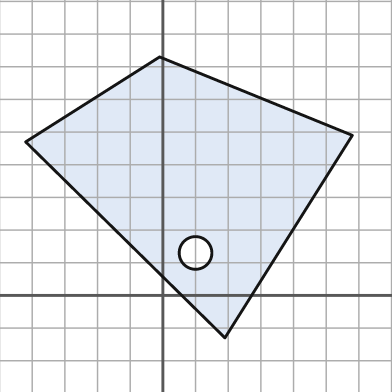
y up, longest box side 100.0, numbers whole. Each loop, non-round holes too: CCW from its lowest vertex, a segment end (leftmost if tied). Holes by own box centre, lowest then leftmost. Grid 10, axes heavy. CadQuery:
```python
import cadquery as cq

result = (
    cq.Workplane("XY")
    .moveTo(19.0, -13.0)
    .lineTo(58.0, 49.0)
    .lineTo(-1.0, 73.0)
    .lineTo(-42.0, 47.0)
    .close()
    .moveTo(10.0, 13.0)
    .circle(5.0)
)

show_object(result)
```